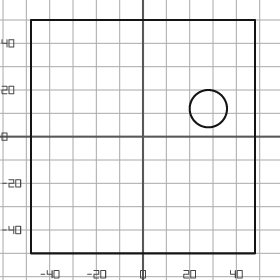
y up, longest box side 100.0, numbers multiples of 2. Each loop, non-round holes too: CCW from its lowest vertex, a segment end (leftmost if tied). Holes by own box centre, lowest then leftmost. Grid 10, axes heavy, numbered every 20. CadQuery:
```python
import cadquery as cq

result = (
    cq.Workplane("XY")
    .moveTo(-48.0, -50.0)
    .lineTo(48.0, -50.0)
    .lineTo(48.0, 50.0)
    .lineTo(-48.0, 50.0)
    .close()
    .moveTo(28.0, 12.0)
    .circle(8.0)
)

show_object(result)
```